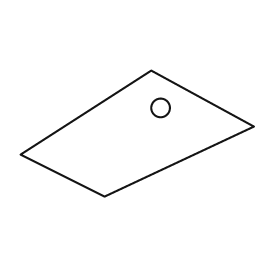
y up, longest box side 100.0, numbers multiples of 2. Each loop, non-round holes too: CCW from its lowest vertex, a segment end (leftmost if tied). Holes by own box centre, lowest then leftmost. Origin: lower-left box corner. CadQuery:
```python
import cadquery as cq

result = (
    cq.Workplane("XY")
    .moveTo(36.0, 0.0)
    .lineTo(100.0, 30.0)
    .lineTo(56.0, 54.0)
    .lineTo(0.0, 18.0)
    .close()
    .moveTo(60.0, 38.0)
    .circle(4.0)
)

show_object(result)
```